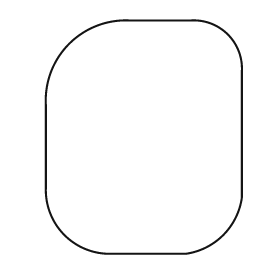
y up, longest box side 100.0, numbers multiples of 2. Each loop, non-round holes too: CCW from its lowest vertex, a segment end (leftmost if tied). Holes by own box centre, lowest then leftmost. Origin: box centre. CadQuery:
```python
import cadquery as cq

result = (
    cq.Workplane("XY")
    .moveTo(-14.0, -50.0)
    .lineTo(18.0, -50.0)
    .threePointArc((34.0, -42.0), (42.0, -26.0))
    .lineTo(42.0, 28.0)
    .threePointArc((36.0, 44.0), (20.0, 50.0))
    .lineTo(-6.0, 50.0)
    .threePointArc((-32.0, 40.0), (-42.0, 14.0))
    .lineTo(-42.0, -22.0)
    .threePointArc((-34.0, -42.0), (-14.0, -50.0))
    .close()
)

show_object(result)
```